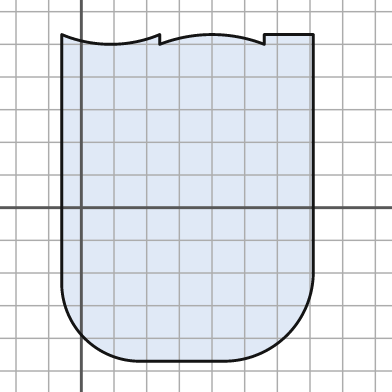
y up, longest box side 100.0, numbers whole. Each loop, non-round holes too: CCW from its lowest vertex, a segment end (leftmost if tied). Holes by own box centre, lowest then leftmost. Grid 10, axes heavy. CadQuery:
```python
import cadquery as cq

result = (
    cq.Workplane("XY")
    .moveTo(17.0, -47.0)
    .lineTo(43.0, -47.0)
    .threePointArc((63.0, -39.0), (71.0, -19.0))
    .lineTo(71.0, 53.0)
    .lineTo(56.0, 53.0)
    .lineTo(56.0, 50.0)
    .threePointArc((40.0, 53.0), (24.0, 50.0))
    .lineTo(24.0, 53.0)
    .threePointArc((9.0, 50.0), (-6.0, 53.0))
    .lineTo(-6.0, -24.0)
    .threePointArc((1.0, -40.0), (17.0, -47.0))
    .close()
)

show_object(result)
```